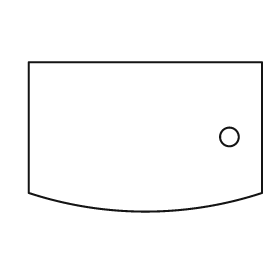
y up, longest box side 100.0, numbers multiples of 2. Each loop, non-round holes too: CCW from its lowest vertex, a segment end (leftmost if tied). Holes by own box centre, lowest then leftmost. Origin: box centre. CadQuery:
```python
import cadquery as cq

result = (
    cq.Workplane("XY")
    .moveTo(-50.0, -24.0)
    .threePointArc((0.0, -32.0), (50.0, -24.0))
    .lineTo(50.0, 32.0)
    .lineTo(-50.0, 32.0)
    .close()
    .moveTo(36.0, 0.0)
    .circle(4.0)
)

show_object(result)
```